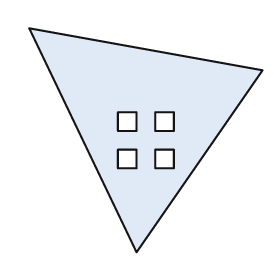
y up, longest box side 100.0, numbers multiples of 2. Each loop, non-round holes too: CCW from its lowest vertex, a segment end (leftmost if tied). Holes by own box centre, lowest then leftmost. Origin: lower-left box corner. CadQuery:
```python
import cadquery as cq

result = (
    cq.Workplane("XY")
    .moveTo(46.0, 0.0)
    .lineTo(100.0, 78.0)
    .lineTo(0.0, 96.0)
    .close()
    .moveTo(38.0, 36.0)
    .lineTo(46.0, 36.0)
    .lineTo(46.0, 44.0)
    .lineTo(38.0, 44.0)
    .close()
    .moveTo(54.0, 36.0)
    .lineTo(62.0, 36.0)
    .lineTo(62.0, 44.0)
    .lineTo(54.0, 44.0)
    .close()
    .moveTo(38.0, 52.0)
    .lineTo(46.0, 52.0)
    .lineTo(46.0, 60.0)
    .lineTo(38.0, 60.0)
    .close()
    .moveTo(54.0, 52.0)
    .lineTo(62.0, 52.0)
    .lineTo(62.0, 60.0)
    .lineTo(54.0, 60.0)
    .close()
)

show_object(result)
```